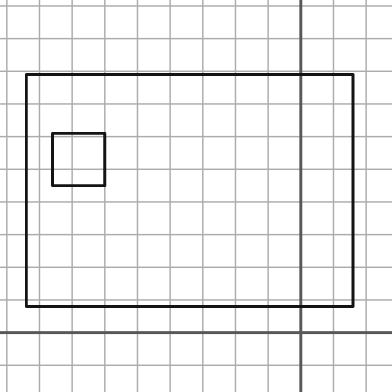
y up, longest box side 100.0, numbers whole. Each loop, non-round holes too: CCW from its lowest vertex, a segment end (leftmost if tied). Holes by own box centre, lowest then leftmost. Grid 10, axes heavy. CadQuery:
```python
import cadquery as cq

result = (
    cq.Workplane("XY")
    .moveTo(-84.0, 8.0)
    .lineTo(16.0, 8.0)
    .lineTo(16.0, 79.0)
    .lineTo(-84.0, 79.0)
    .close()
    .moveTo(-76.0, 45.0)
    .lineTo(-60.0, 45.0)
    .lineTo(-60.0, 61.0)
    .lineTo(-76.0, 61.0)
    .close()
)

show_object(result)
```